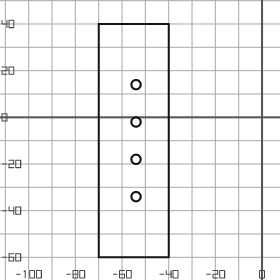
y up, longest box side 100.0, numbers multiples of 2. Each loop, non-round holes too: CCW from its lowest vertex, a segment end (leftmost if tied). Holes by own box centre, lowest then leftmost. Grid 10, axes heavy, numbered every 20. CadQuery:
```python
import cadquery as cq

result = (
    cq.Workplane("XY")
    .moveTo(-70.0, -60.0)
    .lineTo(-40.0, -60.0)
    .lineTo(-40.0, 40.0)
    .lineTo(-70.0, 40.0)
    .close()
    .moveTo(-54.0, -34.0)
    .circle(2.0)
    .moveTo(-54.0, -18.0)
    .circle(2.0)
    .moveTo(-54.0, -2.0)
    .circle(2.0)
    .moveTo(-54.0, 14.0)
    .circle(2.0)
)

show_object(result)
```